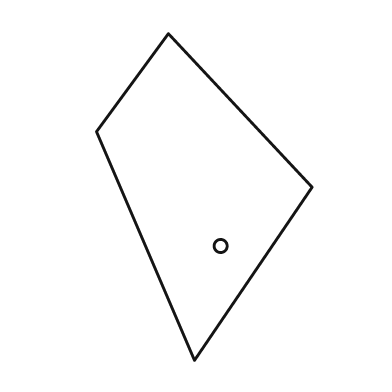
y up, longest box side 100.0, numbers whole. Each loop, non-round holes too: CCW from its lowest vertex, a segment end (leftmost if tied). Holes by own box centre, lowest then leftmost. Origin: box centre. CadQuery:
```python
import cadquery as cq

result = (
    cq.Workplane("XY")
    .moveTo(-3.0, -50.0)
    .lineTo(33.0, 3.0)
    .lineTo(-11.0, 50.0)
    .lineTo(-33.0, 20.0)
    .close()
    .moveTo(5.0, -15.0)
    .circle(2.0)
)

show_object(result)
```